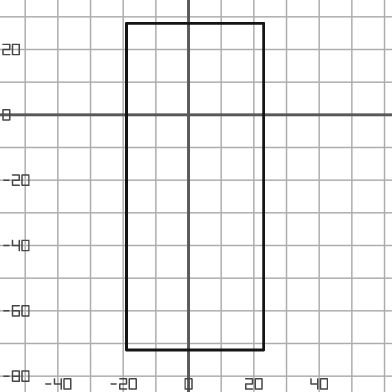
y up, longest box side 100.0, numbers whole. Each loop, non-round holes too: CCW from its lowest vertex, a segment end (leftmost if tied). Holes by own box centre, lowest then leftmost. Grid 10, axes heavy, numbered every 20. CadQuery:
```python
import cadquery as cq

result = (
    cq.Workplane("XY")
    .moveTo(-19.0, -72.0)
    .lineTo(23.0, -72.0)
    .lineTo(23.0, 28.0)
    .lineTo(-19.0, 28.0)
    .close()
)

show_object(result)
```